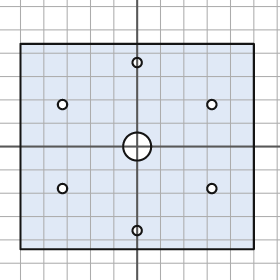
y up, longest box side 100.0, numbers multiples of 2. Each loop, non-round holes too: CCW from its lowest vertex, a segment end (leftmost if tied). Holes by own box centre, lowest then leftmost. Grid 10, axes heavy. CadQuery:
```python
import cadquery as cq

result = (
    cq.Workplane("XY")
    .moveTo(-50.0, -44.0)
    .lineTo(50.0, -44.0)
    .lineTo(50.0, 44.0)
    .lineTo(-50.0, 44.0)
    .close()
    .moveTo(0.0, -36.0)
    .circle(2.0)
    .moveTo(-32.0, -18.0)
    .circle(2.0)
    .moveTo(32.0, -18.0)
    .circle(2.0)
    .moveTo(0.0, 0.0)
    .circle(6.0)
    .moveTo(-32.0, 18.0)
    .circle(2.0)
    .moveTo(32.0, 18.0)
    .circle(2.0)
    .moveTo(0.0, 36.0)
    .circle(2.0)
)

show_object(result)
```